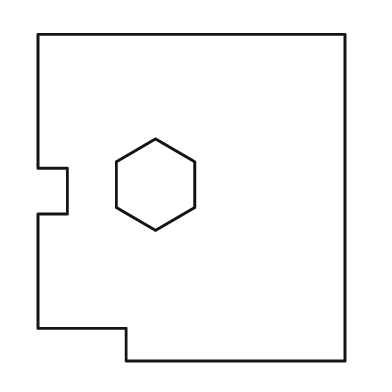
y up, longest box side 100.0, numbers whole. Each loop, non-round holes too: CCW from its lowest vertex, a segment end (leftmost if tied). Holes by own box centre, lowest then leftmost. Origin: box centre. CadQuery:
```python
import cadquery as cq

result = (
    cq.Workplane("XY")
    .moveTo(-20.0, -50.0)
    .lineTo(47.0, -50.0)
    .lineTo(47.0, 50.0)
    .lineTo(-47.0, 50.0)
    .lineTo(-47.0, 9.0)
    .lineTo(-38.0, 9.0)
    .lineTo(-38.0, -5.0)
    .lineTo(-47.0, -5.0)
    .lineTo(-47.0, -40.0)
    .lineTo(-20.0, -40.0)
    .close()
    .moveTo(-11.0, -10.0)
    .lineTo(1.0, -3.0)
    .lineTo(1.0, 11.0)
    .lineTo(-11.0, 18.0)
    .lineTo(-23.0, 11.0)
    .lineTo(-23.0, -3.0)
    .close()
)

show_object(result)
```